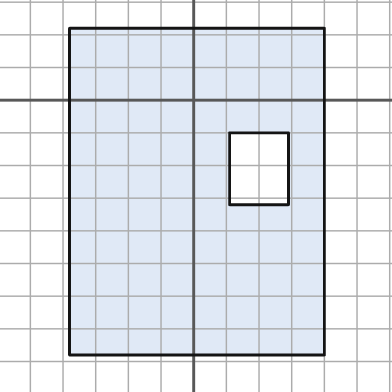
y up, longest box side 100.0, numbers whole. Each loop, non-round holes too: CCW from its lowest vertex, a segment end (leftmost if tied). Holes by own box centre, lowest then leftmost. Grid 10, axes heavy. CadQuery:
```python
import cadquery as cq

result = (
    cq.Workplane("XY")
    .moveTo(-38.0, -78.0)
    .lineTo(40.0, -78.0)
    .lineTo(40.0, 22.0)
    .lineTo(-38.0, 22.0)
    .close()
    .moveTo(11.0, -32.0)
    .lineTo(29.0, -32.0)
    .lineTo(29.0, -10.0)
    .lineTo(11.0, -10.0)
    .close()
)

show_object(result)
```